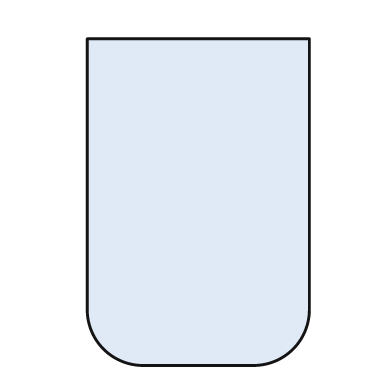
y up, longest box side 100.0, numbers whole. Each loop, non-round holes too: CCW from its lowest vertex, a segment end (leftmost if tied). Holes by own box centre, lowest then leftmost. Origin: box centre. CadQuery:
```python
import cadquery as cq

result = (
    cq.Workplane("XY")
    .moveTo(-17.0, -50.0)
    .lineTo(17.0, -50.0)
    .threePointArc((29.0, -45.0), (34.0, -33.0))
    .lineTo(34.0, 50.0)
    .lineTo(-34.0, 50.0)
    .lineTo(-34.0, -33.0)
    .threePointArc((-29.0, -45.0), (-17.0, -50.0))
    .close()
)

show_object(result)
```